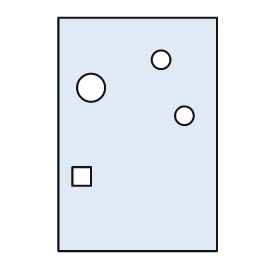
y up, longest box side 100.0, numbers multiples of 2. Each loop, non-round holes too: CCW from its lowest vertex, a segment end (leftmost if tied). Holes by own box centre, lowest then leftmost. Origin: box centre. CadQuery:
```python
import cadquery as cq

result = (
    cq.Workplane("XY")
    .moveTo(-34.0, -50.0)
    .lineTo(34.0, -50.0)
    .lineTo(34.0, 50.0)
    .lineTo(-34.0, 50.0)
    .close()
    .moveTo(-28.0, -22.0)
    .lineTo(-20.0, -22.0)
    .lineTo(-20.0, -14.0)
    .lineTo(-28.0, -14.0)
    .close()
    .moveTo(20.0, 8.0)
    .circle(4.0)
    .moveTo(-20.0, 20.0)
    .circle(6.0)
    .moveTo(10.0, 32.0)
    .circle(4.0)
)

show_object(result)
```